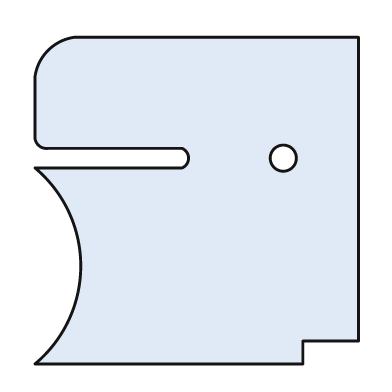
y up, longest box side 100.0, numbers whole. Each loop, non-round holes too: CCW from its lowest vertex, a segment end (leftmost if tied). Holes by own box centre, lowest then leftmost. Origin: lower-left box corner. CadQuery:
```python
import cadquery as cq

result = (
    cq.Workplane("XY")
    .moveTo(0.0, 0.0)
    .lineTo(82.0, 0.0)
    .lineTo(82.0, 7.0)
    .lineTo(99.0, 7.0)
    .lineTo(99.0, 100.0)
    .lineTo(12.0, 100.0)
    .threePointArc((4.0, 96.0), (0.0, 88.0))
    .lineTo(0.0, 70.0)
    .threePointArc((1.0, 67.0), (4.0, 66.0))
    .lineTo(45.0, 66.0)
    .threePointArc((47.0, 63.0), (45.0, 60.0))
    .lineTo(0.0, 60.0)
    .threePointArc((14.0, 30.0), (0.0, 0.0))
    .close()
    .moveTo(76.0, 63.0)
    .circle(4.0)
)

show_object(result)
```